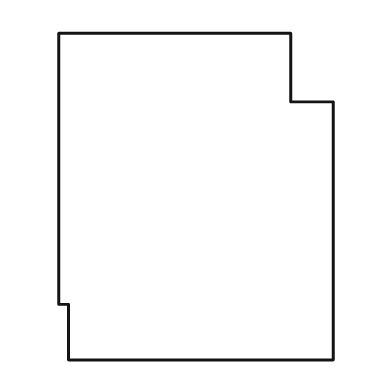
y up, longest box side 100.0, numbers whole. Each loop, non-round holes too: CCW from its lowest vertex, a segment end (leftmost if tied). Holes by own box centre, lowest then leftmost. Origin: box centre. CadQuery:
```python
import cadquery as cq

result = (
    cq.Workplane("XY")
    .moveTo(-39.0, -50.0)
    .lineTo(42.0, -50.0)
    .lineTo(42.0, 29.0)
    .lineTo(29.0, 29.0)
    .lineTo(29.0, 50.0)
    .lineTo(-42.0, 50.0)
    .lineTo(-42.0, -33.0)
    .lineTo(-39.0, -33.0)
    .close()
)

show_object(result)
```